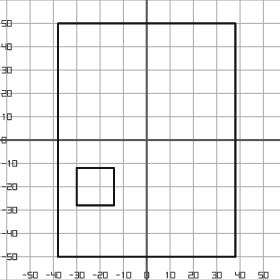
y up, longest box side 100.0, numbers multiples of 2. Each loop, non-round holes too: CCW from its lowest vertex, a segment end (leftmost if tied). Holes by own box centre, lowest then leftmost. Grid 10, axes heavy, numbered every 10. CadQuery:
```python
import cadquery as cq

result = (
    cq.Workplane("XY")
    .moveTo(-38.0, -50.0)
    .lineTo(38.0, -50.0)
    .lineTo(38.0, 50.0)
    .lineTo(-38.0, 50.0)
    .close()
    .moveTo(-30.0, -28.0)
    .lineTo(-14.0, -28.0)
    .lineTo(-14.0, -12.0)
    .lineTo(-30.0, -12.0)
    .close()
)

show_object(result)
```